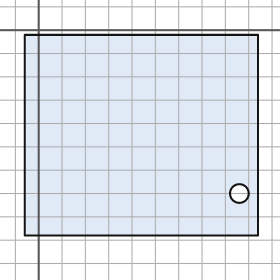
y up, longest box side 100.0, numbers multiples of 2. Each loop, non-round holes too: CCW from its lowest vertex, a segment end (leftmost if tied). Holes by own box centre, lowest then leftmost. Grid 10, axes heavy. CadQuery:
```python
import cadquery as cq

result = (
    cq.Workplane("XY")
    .moveTo(-6.0, -88.0)
    .lineTo(94.0, -88.0)
    .lineTo(94.0, -2.0)
    .lineTo(-6.0, -2.0)
    .close()
    .moveTo(86.0, -70.0)
    .circle(4.0)
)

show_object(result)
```